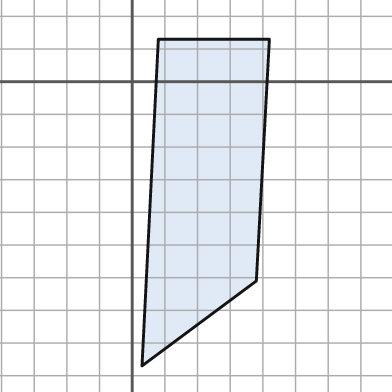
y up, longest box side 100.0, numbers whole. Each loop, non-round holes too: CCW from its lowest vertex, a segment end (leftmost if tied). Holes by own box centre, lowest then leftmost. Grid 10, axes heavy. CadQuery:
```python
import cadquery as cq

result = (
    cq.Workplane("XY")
    .moveTo(3.0, -87.0)
    .lineTo(38.0, -61.0)
    .lineTo(42.0, 13.0)
    .lineTo(8.0, 13.0)
    .close()
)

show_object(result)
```